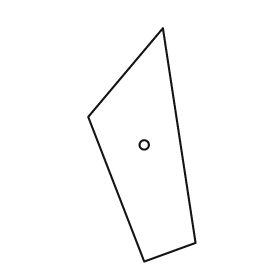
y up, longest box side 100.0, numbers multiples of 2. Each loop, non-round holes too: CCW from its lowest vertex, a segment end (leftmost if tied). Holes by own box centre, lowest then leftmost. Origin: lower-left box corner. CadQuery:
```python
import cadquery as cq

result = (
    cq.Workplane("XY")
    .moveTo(24.0, 0.0)
    .lineTo(46.0, 8.0)
    .lineTo(32.0, 100.0)
    .lineTo(0.0, 62.0)
    .close()
    .moveTo(24.0, 50.0)
    .circle(2.0)
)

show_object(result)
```